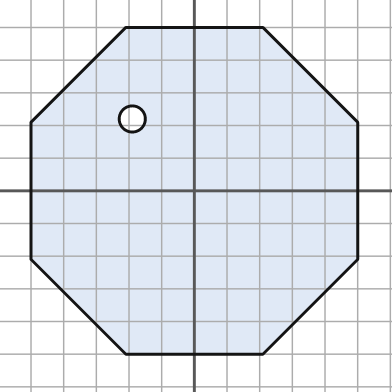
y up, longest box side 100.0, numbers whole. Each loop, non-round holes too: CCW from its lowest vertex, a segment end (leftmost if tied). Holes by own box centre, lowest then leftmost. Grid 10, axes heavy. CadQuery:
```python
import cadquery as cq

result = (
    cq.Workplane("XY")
    .moveTo(-21.0, -50.0)
    .lineTo(21.0, -50.0)
    .lineTo(50.0, -21.0)
    .lineTo(50.0, 21.0)
    .lineTo(21.0, 50.0)
    .lineTo(-21.0, 50.0)
    .lineTo(-50.0, 21.0)
    .lineTo(-50.0, -21.0)
    .close()
    .moveTo(-19.0, 22.0)
    .circle(4.0)
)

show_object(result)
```